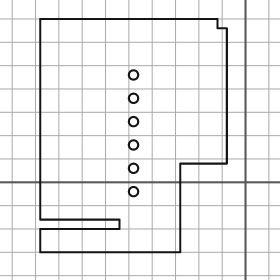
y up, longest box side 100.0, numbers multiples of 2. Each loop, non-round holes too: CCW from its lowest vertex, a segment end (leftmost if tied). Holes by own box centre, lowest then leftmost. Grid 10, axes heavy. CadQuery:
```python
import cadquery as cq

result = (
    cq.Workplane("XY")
    .moveTo(-88.0, -30.0)
    .lineTo(-28.0, -30.0)
    .lineTo(-28.0, 8.0)
    .lineTo(-8.0, 8.0)
    .lineTo(-8.0, 66.0)
    .lineTo(-12.0, 66.0)
    .lineTo(-12.0, 70.0)
    .lineTo(-88.0, 70.0)
    .lineTo(-88.0, -16.0)
    .lineTo(-54.0, -16.0)
    .lineTo(-54.0, -20.0)
    .lineTo(-88.0, -20.0)
    .close()
    .moveTo(-48.0, -4.0)
    .circle(2.0)
    .moveTo(-48.0, 6.0)
    .circle(2.0)
    .moveTo(-48.0, 16.0)
    .circle(2.0)
    .moveTo(-48.0, 26.0)
    .circle(2.0)
    .moveTo(-48.0, 36.0)
    .circle(2.0)
    .moveTo(-48.0, 46.0)
    .circle(2.0)
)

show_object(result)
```